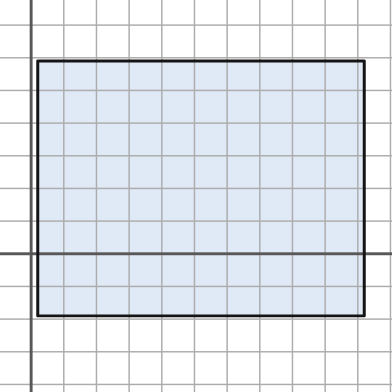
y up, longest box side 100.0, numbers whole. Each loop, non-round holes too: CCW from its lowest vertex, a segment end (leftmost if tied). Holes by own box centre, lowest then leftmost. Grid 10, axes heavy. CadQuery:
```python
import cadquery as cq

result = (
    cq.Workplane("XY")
    .moveTo(2.0, -19.0)
    .lineTo(102.0, -19.0)
    .lineTo(102.0, 59.0)
    .lineTo(2.0, 59.0)
    .close()
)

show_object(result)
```